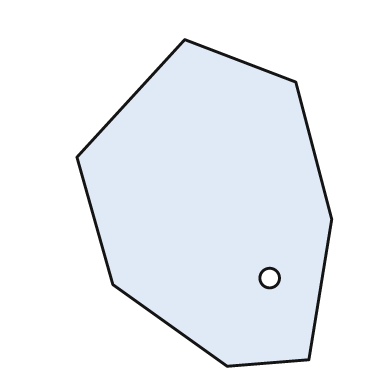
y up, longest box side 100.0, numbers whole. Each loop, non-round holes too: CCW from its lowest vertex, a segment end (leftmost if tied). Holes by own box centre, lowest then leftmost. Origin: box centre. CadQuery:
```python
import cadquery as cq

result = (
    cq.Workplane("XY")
    .moveTo(7.0, -50.0)
    .lineTo(32.0, -48.0)
    .lineTo(39.0, -5.0)
    .lineTo(28.0, 37.0)
    .lineTo(-6.0, 50.0)
    .lineTo(-39.0, 14.0)
    .lineTo(-28.0, -25.0)
    .close()
    .moveTo(20.0, -23.0)
    .circle(3.0)
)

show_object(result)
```